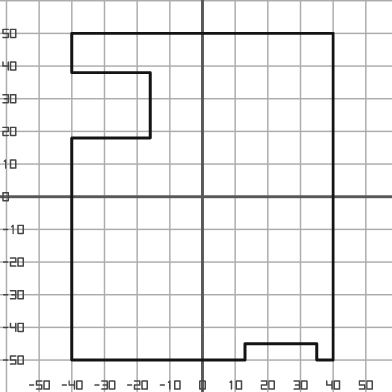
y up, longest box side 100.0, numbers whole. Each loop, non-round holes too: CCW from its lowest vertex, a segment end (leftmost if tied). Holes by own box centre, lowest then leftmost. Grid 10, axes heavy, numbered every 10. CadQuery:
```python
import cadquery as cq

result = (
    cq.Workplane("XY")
    .moveTo(-40.0, -50.0)
    .lineTo(13.0, -50.0)
    .lineTo(13.0, -45.0)
    .lineTo(35.0, -45.0)
    .lineTo(35.0, -50.0)
    .lineTo(40.0, -50.0)
    .lineTo(40.0, 50.0)
    .lineTo(-40.0, 50.0)
    .lineTo(-40.0, 38.0)
    .lineTo(-16.0, 38.0)
    .lineTo(-16.0, 18.0)
    .lineTo(-40.0, 18.0)
    .close()
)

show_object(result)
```